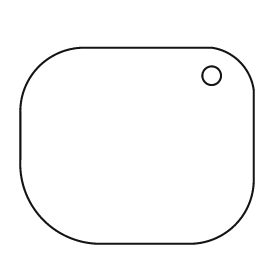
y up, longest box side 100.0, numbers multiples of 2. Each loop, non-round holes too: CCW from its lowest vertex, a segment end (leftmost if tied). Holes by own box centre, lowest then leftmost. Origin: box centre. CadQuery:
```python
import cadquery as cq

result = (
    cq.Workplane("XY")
    .moveTo(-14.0, -42.0)
    .lineTo(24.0, -42.0)
    .threePointArc((42.0, -34.0), (50.0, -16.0))
    .lineTo(50.0, 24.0)
    .threePointArc((44.0, 36.0), (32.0, 42.0))
    .lineTo(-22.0, 42.0)
    .threePointArc((-42.0, 34.0), (-50.0, 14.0))
    .lineTo(-50.0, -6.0)
    .threePointArc((-40.0, -32.0), (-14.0, -42.0))
    .close()
    .moveTo(32.0, 30.0)
    .circle(4.0)
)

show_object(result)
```